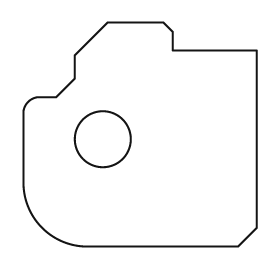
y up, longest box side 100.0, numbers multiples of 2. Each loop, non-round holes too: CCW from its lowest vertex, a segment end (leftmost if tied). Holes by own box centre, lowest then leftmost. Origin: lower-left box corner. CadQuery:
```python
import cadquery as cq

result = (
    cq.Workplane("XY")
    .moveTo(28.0, 0.0)
    .lineTo(92.0, 0.0)
    .lineTo(100.0, 8.0)
    .lineTo(100.0, 84.0)
    .lineTo(64.0, 84.0)
    .lineTo(64.0, 92.0)
    .lineTo(60.0, 96.0)
    .lineTo(36.0, 96.0)
    .lineTo(22.0, 82.0)
    .lineTo(22.0, 72.0)
    .lineTo(14.0, 64.0)
    .lineTo(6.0, 64.0)
    .threePointArc((2.0, 62.0), (0.0, 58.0))
    .lineTo(0.0, 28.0)
    .threePointArc((8.0, 8.0), (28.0, 0.0))
    .close()
    .moveTo(34.0, 46.0)
    .circle(12.0)
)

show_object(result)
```